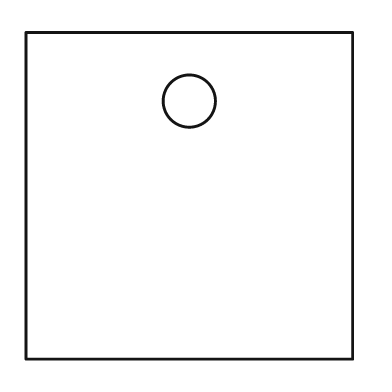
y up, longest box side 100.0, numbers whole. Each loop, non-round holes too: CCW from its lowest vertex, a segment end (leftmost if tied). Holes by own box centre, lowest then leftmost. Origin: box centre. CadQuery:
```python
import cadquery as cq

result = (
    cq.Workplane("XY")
    .moveTo(-50.0, -50.0)
    .lineTo(50.0, -50.0)
    .lineTo(50.0, 50.0)
    .lineTo(-50.0, 50.0)
    .close()
    .moveTo(0.0, 29.0)
    .circle(8.0)
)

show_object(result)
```